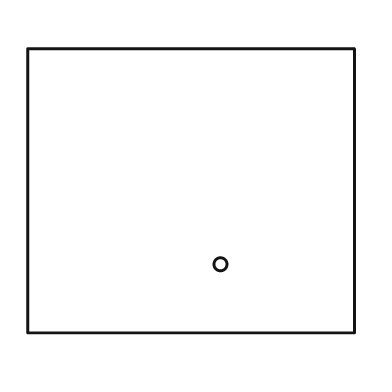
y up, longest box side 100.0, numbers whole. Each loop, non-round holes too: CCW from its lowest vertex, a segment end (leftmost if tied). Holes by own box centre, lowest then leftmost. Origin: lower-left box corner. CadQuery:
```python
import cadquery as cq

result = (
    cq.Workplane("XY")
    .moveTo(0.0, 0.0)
    .lineTo(100.0, 0.0)
    .lineTo(100.0, 87.0)
    .lineTo(0.0, 87.0)
    .close()
    .moveTo(59.0, 21.0)
    .circle(2.0)
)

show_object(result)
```